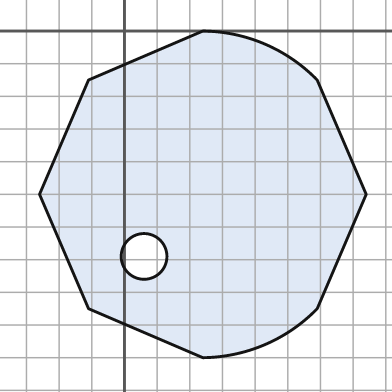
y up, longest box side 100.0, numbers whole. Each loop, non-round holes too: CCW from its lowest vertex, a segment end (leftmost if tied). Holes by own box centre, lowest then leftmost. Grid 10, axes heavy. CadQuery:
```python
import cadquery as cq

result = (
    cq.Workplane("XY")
    .moveTo(24.0, -100.0)
    .threePointArc((43.0, -96.0), (59.0, -85.0))
    .lineTo(74.0, -50.0)
    .lineTo(59.0, -15.0)
    .threePointArc((43.0, -4.0), (24.0, 0.0))
    .lineTo(-11.0, -15.0)
    .lineTo(-26.0, -50.0)
    .lineTo(-11.0, -85.0)
    .close()
    .moveTo(6.0, -69.0)
    .circle(7.0)
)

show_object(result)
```